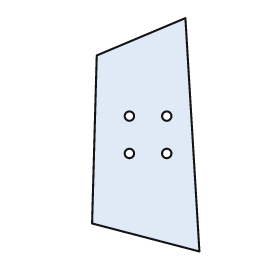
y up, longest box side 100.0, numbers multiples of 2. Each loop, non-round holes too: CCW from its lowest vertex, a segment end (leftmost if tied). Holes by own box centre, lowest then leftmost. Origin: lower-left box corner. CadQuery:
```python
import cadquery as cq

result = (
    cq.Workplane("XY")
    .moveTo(46.0, 0.0)
    .lineTo(40.0, 100.0)
    .lineTo(2.0, 84.0)
    .lineTo(0.0, 12.0)
    .close()
    .moveTo(16.0, 42.0)
    .circle(2.0)
    .moveTo(32.0, 42.0)
    .circle(2.0)
    .moveTo(16.0, 58.0)
    .circle(2.0)
    .moveTo(32.0, 58.0)
    .circle(2.0)
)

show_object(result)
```